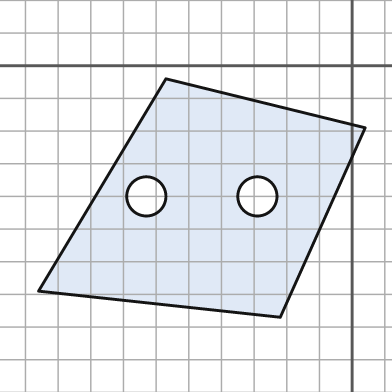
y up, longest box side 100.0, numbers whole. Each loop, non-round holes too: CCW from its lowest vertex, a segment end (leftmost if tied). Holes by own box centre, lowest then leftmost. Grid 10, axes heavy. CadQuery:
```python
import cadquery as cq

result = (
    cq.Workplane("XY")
    .moveTo(-22.0, -77.0)
    .lineTo(4.0, -19.0)
    .lineTo(-57.0, -4.0)
    .lineTo(-96.0, -69.0)
    .close()
    .moveTo(-63.0, -40.0)
    .circle(6.0)
    .moveTo(-29.0, -40.0)
    .circle(6.0)
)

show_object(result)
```